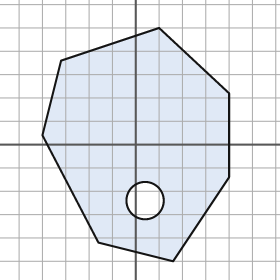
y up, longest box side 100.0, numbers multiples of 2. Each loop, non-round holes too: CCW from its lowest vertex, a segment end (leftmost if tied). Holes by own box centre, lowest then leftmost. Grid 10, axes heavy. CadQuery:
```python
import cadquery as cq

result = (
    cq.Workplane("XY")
    .moveTo(16.0, -50.0)
    .lineTo(40.0, -14.0)
    .lineTo(40.0, 22.0)
    .lineTo(10.0, 50.0)
    .lineTo(-32.0, 36.0)
    .lineTo(-40.0, 4.0)
    .lineTo(-16.0, -42.0)
    .close()
    .moveTo(4.0, -24.0)
    .circle(8.0)
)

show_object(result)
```